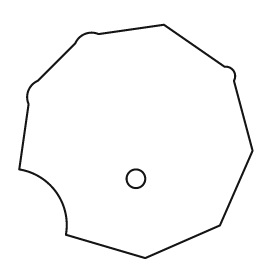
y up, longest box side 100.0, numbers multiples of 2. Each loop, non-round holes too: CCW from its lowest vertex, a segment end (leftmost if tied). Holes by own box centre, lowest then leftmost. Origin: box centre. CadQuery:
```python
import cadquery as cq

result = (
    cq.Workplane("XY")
    .moveTo(4.0, -50.0)
    .lineTo(36.0, -36.0)
    .lineTo(50.0, -4.0)
    .lineTo(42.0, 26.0)
    .threePointArc((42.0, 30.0), (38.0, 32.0))
    .lineTo(12.0, 50.0)
    .lineTo(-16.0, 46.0)
    .threePointArc((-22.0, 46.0), (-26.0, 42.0))
    .lineTo(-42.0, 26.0)
    .threePointArc((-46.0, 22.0), (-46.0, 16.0))
    .lineTo(-50.0, -12.0)
    .threePointArc((-34.0, -22.0), (-30.0, -40.0))
    .close()
    .moveTo(0.0, -16.0)
    .circle(4.0)
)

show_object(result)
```